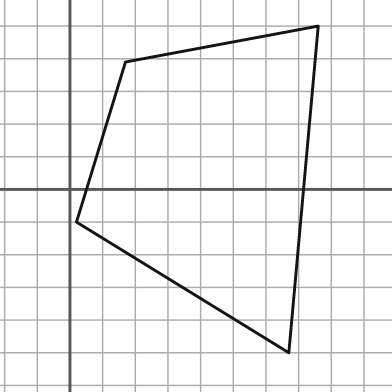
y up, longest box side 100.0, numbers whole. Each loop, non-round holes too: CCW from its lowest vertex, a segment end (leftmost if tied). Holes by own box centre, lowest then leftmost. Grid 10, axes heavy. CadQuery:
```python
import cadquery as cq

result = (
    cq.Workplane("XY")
    .moveTo(67.0, -50.0)
    .lineTo(76.0, 50.0)
    .lineTo(17.0, 39.0)
    .lineTo(2.0, -10.0)
    .close()
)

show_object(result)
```